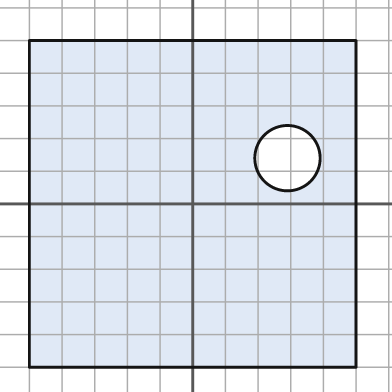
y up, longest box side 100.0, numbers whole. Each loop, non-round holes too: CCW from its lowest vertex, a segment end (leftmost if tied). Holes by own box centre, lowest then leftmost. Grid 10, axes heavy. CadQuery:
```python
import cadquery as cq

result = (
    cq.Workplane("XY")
    .moveTo(-50.0, -50.0)
    .lineTo(50.0, -50.0)
    .lineTo(50.0, 50.0)
    .lineTo(-50.0, 50.0)
    .close()
    .moveTo(29.0, 14.0)
    .circle(10.0)
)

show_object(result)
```